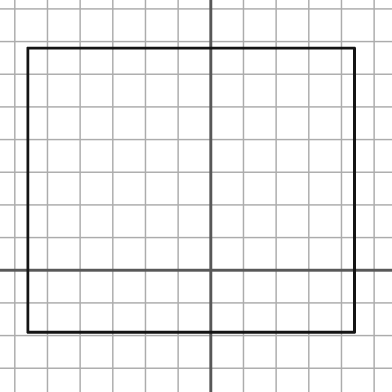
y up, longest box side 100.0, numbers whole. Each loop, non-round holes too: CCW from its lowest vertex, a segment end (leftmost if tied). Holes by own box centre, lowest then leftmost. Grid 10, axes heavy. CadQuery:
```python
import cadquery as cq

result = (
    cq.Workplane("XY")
    .moveTo(-56.0, -19.0)
    .lineTo(44.0, -19.0)
    .lineTo(44.0, 68.0)
    .lineTo(-56.0, 68.0)
    .close()
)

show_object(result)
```